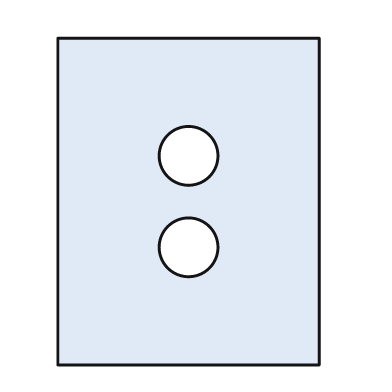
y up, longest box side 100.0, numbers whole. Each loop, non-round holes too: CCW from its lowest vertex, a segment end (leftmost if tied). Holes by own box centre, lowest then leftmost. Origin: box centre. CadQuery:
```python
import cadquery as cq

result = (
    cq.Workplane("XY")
    .moveTo(-40.0, -50.0)
    .lineTo(40.0, -50.0)
    .lineTo(40.0, 50.0)
    .lineTo(-40.0, 50.0)
    .close()
    .moveTo(0.0, -14.0)
    .circle(9.0)
    .moveTo(0.0, 14.0)
    .circle(9.0)
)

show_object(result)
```